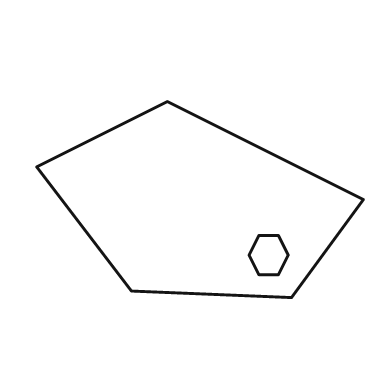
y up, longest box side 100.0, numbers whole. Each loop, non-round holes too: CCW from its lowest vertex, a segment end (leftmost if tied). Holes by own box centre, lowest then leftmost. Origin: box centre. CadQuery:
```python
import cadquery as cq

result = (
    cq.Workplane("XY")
    .moveTo(28.0, -30.0)
    .lineTo(50.0, 0.0)
    .lineTo(-10.0, 30.0)
    .lineTo(-50.0, 10.0)
    .lineTo(-21.0, -28.0)
    .close()
    .moveTo(18.0, -23.0)
    .lineTo(24.0, -23.0)
    .lineTo(27.0, -17.0)
    .lineTo(24.0, -11.0)
    .lineTo(18.0, -11.0)
    .lineTo(15.0, -17.0)
    .close()
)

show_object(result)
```